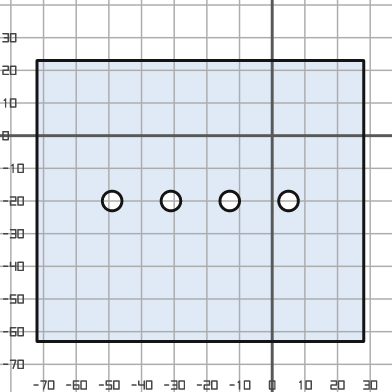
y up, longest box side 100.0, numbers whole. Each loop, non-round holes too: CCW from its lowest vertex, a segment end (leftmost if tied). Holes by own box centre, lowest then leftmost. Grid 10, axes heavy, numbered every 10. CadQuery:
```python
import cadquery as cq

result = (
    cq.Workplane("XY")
    .moveTo(-72.0, -63.0)
    .lineTo(28.0, -63.0)
    .lineTo(28.0, 23.0)
    .lineTo(-72.0, 23.0)
    .close()
    .moveTo(-49.0, -20.0)
    .circle(3.0)
    .moveTo(-31.0, -20.0)
    .circle(3.0)
    .moveTo(-13.0, -20.0)
    .circle(3.0)
    .moveTo(5.0, -20.0)
    .circle(3.0)
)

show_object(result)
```